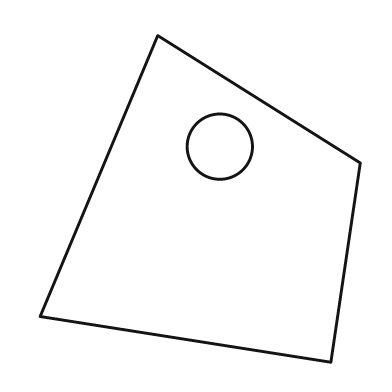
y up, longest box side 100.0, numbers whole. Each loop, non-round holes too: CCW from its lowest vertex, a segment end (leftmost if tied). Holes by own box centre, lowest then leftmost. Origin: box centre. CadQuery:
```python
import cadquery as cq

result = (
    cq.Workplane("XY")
    .moveTo(40.0, -50.0)
    .lineTo(49.0, 11.0)
    .lineTo(-13.0, 50.0)
    .lineTo(-49.0, -36.0)
    .close()
    .moveTo(6.0, 16.0)
    .circle(10.0)
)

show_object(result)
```